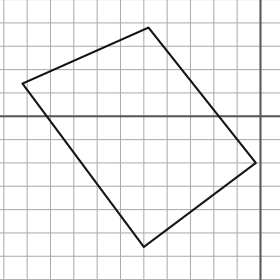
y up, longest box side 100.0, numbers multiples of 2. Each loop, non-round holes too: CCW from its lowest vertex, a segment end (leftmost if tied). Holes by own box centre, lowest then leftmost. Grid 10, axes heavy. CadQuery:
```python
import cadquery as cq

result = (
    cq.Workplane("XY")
    .moveTo(-50.0, -56.0)
    .lineTo(-2.0, -20.0)
    .lineTo(-48.0, 38.0)
    .lineTo(-102.0, 14.0)
    .close()
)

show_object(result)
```